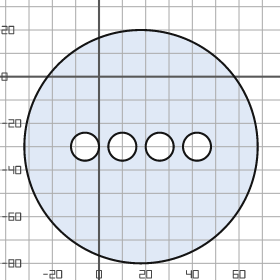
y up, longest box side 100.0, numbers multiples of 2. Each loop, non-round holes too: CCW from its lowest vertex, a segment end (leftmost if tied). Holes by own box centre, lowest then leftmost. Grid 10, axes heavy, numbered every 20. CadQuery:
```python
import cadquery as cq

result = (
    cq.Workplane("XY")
    .moveTo(18.0, -30.0)
    .circle(50.0)
    .moveTo(-6.0, -30.0)
    .circle(6.0)
    .moveTo(10.0, -30.0)
    .circle(6.0)
    .moveTo(26.0, -30.0)
    .circle(6.0)
    .moveTo(42.0, -30.0)
    .circle(6.0)
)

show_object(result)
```